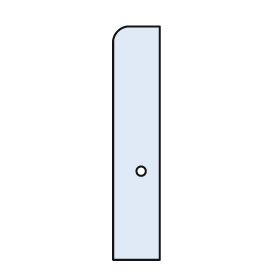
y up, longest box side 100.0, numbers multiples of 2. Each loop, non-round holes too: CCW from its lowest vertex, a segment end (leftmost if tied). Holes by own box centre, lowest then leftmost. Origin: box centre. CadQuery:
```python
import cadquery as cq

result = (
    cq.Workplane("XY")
    .moveTo(-10.0, -50.0)
    .lineTo(10.0, -50.0)
    .lineTo(10.0, 50.0)
    .lineTo(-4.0, 50.0)
    .threePointArc((-8.0, 48.0), (-10.0, 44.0))
    .close()
    .moveTo(2.0, -12.0)
    .circle(2.0)
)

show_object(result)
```